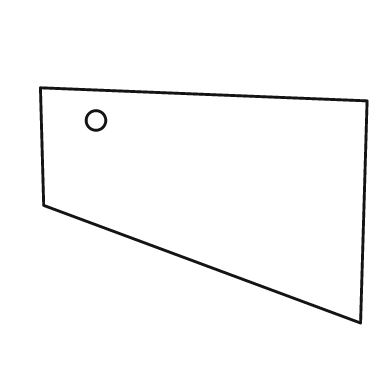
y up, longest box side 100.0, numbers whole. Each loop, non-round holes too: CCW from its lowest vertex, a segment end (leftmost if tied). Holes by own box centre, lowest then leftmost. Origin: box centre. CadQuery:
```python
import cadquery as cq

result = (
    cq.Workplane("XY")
    .moveTo(48.0, -36.0)
    .lineTo(50.0, 32.0)
    .lineTo(-50.0, 36.0)
    .lineTo(-49.0, 0.0)
    .close()
    .moveTo(-33.0, 26.0)
    .circle(3.0)
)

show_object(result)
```